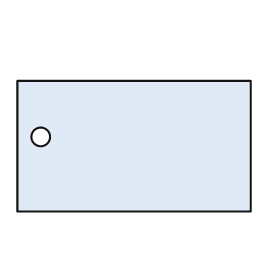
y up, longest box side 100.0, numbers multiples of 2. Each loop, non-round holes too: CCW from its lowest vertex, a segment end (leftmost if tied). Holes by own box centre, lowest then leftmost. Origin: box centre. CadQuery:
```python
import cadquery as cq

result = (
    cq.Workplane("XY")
    .moveTo(-50.0, -28.0)
    .lineTo(50.0, -28.0)
    .lineTo(50.0, 28.0)
    .lineTo(-50.0, 28.0)
    .close()
    .moveTo(-40.0, 4.0)
    .circle(4.0)
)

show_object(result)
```